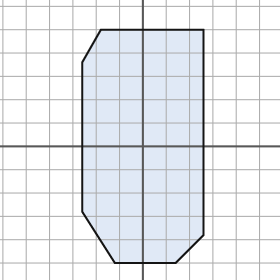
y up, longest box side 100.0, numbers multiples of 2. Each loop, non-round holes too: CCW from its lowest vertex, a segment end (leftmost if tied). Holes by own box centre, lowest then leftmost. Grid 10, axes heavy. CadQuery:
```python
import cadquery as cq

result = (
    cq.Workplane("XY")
    .moveTo(-12.0, -50.0)
    .lineTo(14.0, -50.0)
    .lineTo(26.0, -38.0)
    .lineTo(26.0, 50.0)
    .lineTo(-18.0, 50.0)
    .lineTo(-26.0, 36.0)
    .lineTo(-26.0, -28.0)
    .close()
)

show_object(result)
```